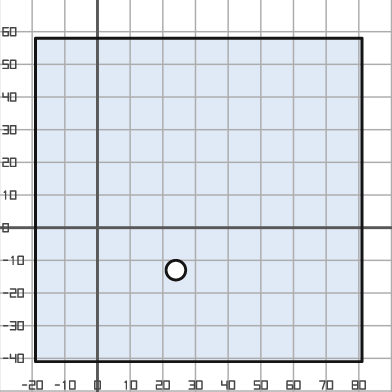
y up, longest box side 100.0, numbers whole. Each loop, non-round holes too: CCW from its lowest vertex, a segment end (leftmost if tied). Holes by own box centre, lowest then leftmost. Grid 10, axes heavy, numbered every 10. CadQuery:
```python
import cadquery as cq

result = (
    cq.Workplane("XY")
    .moveTo(-19.0, -41.0)
    .lineTo(81.0, -41.0)
    .lineTo(81.0, 58.0)
    .lineTo(-19.0, 58.0)
    .close()
    .moveTo(24.0, -13.0)
    .circle(3.0)
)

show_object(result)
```